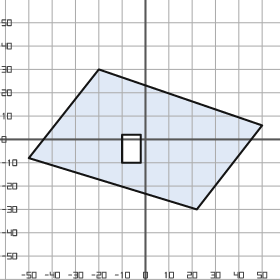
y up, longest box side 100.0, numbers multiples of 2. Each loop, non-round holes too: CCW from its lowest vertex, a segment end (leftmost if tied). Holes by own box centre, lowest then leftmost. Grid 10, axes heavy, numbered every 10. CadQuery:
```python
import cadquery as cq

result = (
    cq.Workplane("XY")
    .moveTo(22.0, -30.0)
    .lineTo(50.0, 6.0)
    .lineTo(-20.0, 30.0)
    .lineTo(-50.0, -8.0)
    .close()
    .moveTo(-10.0, -10.0)
    .lineTo(-2.0, -10.0)
    .lineTo(-2.0, 2.0)
    .lineTo(-10.0, 2.0)
    .close()
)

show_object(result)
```